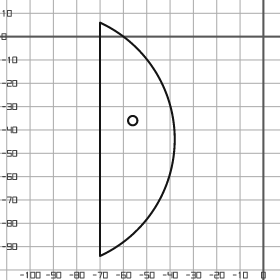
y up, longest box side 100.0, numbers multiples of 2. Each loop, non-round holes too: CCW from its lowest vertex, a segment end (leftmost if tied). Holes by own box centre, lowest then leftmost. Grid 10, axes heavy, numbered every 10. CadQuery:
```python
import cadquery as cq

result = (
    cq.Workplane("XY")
    .moveTo(-70.0, -94.0)
    .threePointArc((-38.0, -44.0), (-70.0, 6.0))
    .close()
    .moveTo(-56.0, -36.0)
    .circle(2.0)
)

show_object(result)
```